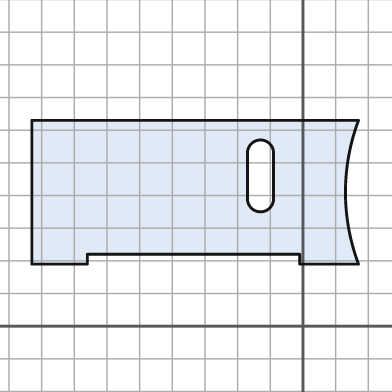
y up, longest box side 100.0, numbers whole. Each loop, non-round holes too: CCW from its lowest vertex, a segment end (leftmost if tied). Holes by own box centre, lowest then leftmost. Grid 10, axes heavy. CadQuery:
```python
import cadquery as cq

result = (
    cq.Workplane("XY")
    .moveTo(-83.0, 19.0)
    .lineTo(-66.0, 19.0)
    .lineTo(-66.0, 22.0)
    .lineTo(-1.0, 22.0)
    .lineTo(-1.0, 19.0)
    .lineTo(17.0, 19.0)
    .threePointArc((13.0, 41.0), (17.0, 63.0))
    .lineTo(-83.0, 63.0)
    .close()
    .moveTo(-17.0, 39.0)
    .threePointArc((-13.0, 35.0), (-9.0, 39.0))
    .lineTo(-9.0, 53.0)
    .threePointArc((-13.0, 57.0), (-17.0, 53.0))
    .close()
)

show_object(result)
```